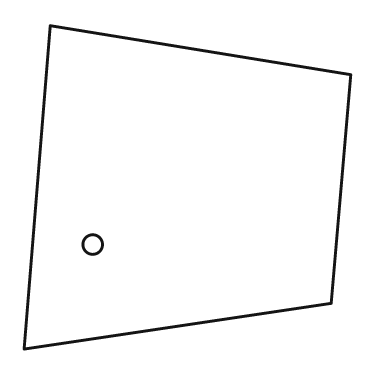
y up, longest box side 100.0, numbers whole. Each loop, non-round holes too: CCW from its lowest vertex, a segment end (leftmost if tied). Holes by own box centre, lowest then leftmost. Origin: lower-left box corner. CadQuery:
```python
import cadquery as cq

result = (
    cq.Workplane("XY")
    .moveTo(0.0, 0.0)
    .lineTo(94.0, 14.0)
    .lineTo(100.0, 84.0)
    .lineTo(8.0, 99.0)
    .close()
    .moveTo(21.0, 32.0)
    .circle(3.0)
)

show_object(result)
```